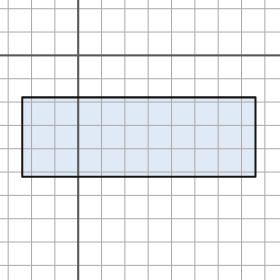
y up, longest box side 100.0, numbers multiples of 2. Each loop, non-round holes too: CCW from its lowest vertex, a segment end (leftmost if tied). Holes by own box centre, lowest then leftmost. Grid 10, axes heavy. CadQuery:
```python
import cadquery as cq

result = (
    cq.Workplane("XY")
    .moveTo(-24.0, -52.0)
    .lineTo(76.0, -52.0)
    .lineTo(76.0, -18.0)
    .lineTo(-24.0, -18.0)
    .close()
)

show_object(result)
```